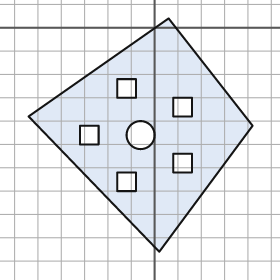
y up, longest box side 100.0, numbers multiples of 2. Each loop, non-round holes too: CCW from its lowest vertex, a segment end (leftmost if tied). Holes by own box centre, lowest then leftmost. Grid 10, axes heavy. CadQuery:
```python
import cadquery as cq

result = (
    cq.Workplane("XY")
    .moveTo(2.0, -96.0)
    .lineTo(42.0, -42.0)
    .lineTo(6.0, 4.0)
    .lineTo(-54.0, -38.0)
    .close()
    .moveTo(-16.0, -70.0)
    .lineTo(-8.0, -70.0)
    .lineTo(-8.0, -62.0)
    .lineTo(-16.0, -62.0)
    .close()
    .moveTo(8.0, -62.0)
    .lineTo(16.0, -62.0)
    .lineTo(16.0, -54.0)
    .lineTo(8.0, -54.0)
    .close()
    .moveTo(-32.0, -50.0)
    .lineTo(-24.0, -50.0)
    .lineTo(-24.0, -42.0)
    .lineTo(-32.0, -42.0)
    .close()
    .moveTo(-6.0, -46.0)
    .circle(6.0)
    .moveTo(8.0, -38.0)
    .lineTo(16.0, -38.0)
    .lineTo(16.0, -30.0)
    .lineTo(8.0, -30.0)
    .close()
    .moveTo(-16.0, -30.0)
    .lineTo(-8.0, -30.0)
    .lineTo(-8.0, -22.0)
    .lineTo(-16.0, -22.0)
    .close()
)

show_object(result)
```